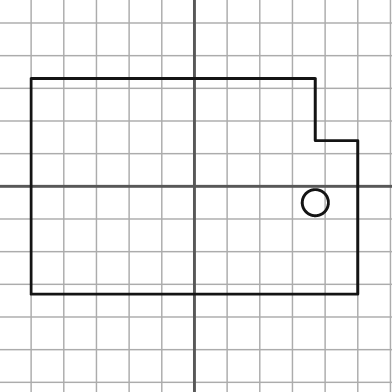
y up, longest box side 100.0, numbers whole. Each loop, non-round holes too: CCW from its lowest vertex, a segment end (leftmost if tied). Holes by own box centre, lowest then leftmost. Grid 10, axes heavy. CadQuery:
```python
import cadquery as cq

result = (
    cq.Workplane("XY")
    .moveTo(-50.0, -33.0)
    .lineTo(50.0, -33.0)
    .lineTo(50.0, 14.0)
    .lineTo(37.0, 14.0)
    .lineTo(37.0, 33.0)
    .lineTo(-50.0, 33.0)
    .close()
    .moveTo(37.0, -5.0)
    .circle(4.0)
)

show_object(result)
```